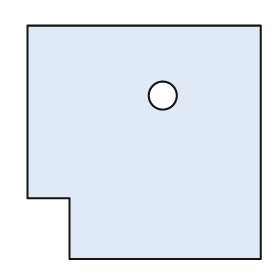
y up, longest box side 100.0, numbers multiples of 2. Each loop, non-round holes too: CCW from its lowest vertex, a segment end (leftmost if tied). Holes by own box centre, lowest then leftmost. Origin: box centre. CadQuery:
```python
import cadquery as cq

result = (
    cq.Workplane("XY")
    .moveTo(-32.0, -50.0)
    .lineTo(50.0, -50.0)
    .lineTo(50.0, 50.0)
    .lineTo(-50.0, 50.0)
    .lineTo(-50.0, -24.0)
    .lineTo(-32.0, -24.0)
    .close()
    .moveTo(8.0, 20.0)
    .circle(6.0)
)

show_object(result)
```